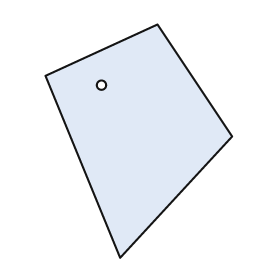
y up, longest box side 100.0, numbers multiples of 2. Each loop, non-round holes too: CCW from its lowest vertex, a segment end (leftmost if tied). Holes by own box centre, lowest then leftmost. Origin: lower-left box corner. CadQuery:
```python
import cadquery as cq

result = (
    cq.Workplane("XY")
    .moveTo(32.0, 0.0)
    .lineTo(80.0, 52.0)
    .lineTo(48.0, 100.0)
    .lineTo(0.0, 78.0)
    .close()
    .moveTo(24.0, 74.0)
    .circle(2.0)
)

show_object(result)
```